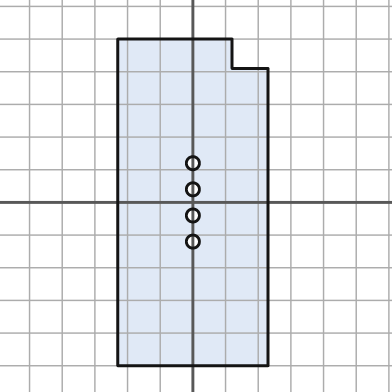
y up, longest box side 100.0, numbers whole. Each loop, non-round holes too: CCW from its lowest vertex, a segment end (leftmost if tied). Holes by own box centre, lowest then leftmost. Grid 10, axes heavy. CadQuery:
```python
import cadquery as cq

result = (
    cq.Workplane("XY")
    .moveTo(-23.0, -50.0)
    .lineTo(23.0, -50.0)
    .lineTo(23.0, 41.0)
    .lineTo(12.0, 41.0)
    .lineTo(12.0, 50.0)
    .lineTo(-23.0, 50.0)
    .close()
    .moveTo(0.0, -12.0)
    .circle(2.0)
    .moveTo(0.0, -4.0)
    .circle(2.0)
    .moveTo(0.0, 4.0)
    .circle(2.0)
    .moveTo(0.0, 12.0)
    .circle(2.0)
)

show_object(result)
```